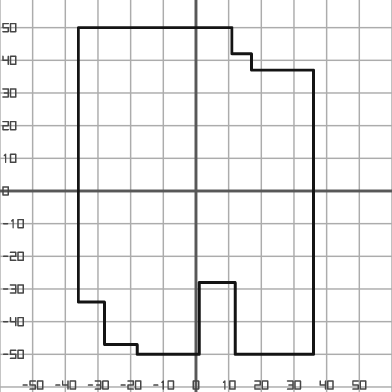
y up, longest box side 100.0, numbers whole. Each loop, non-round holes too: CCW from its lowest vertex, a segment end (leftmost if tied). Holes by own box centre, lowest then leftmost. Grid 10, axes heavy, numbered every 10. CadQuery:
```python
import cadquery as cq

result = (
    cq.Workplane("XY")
    .moveTo(-18.0, -50.0)
    .lineTo(1.0, -50.0)
    .lineTo(1.0, -28.0)
    .lineTo(12.0, -28.0)
    .lineTo(12.0, -50.0)
    .lineTo(36.0, -50.0)
    .lineTo(36.0, 37.0)
    .lineTo(17.0, 37.0)
    .lineTo(17.0, 42.0)
    .lineTo(11.0, 42.0)
    .lineTo(11.0, 50.0)
    .lineTo(-36.0, 50.0)
    .lineTo(-36.0, -34.0)
    .lineTo(-28.0, -34.0)
    .lineTo(-28.0, -47.0)
    .lineTo(-18.0, -47.0)
    .close()
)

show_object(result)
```